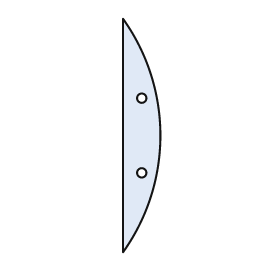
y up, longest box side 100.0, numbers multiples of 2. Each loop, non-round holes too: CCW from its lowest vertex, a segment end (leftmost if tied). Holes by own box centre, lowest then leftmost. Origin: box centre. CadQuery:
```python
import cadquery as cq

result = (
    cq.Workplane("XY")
    .moveTo(-8.0, -50.0)
    .threePointArc((8.0, 0.0), (-8.0, 50.0))
    .close()
    .moveTo(0.0, -16.0)
    .circle(2.0)
    .moveTo(0.0, 16.0)
    .circle(2.0)
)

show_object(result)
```